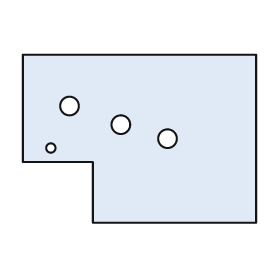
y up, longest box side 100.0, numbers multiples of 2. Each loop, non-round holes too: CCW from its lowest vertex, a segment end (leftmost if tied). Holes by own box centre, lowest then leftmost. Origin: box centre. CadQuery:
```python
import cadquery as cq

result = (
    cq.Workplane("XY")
    .moveTo(-20.0, -36.0)
    .lineTo(50.0, -36.0)
    .lineTo(50.0, 36.0)
    .lineTo(-50.0, 36.0)
    .lineTo(-50.0, -10.0)
    .lineTo(-20.0, -10.0)
    .close()
    .moveTo(-38.0, -4.0)
    .circle(2.0)
    .moveTo(12.0, 0.0)
    .circle(4.0)
    .moveTo(-8.0, 6.0)
    .circle(4.0)
    .moveTo(-30.0, 14.0)
    .circle(4.0)
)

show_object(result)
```